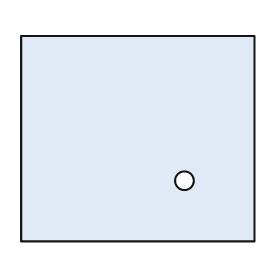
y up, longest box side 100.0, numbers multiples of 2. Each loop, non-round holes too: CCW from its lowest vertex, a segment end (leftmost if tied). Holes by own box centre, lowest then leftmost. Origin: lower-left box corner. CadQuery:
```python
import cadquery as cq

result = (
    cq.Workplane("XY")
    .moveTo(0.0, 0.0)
    .lineTo(100.0, 0.0)
    .lineTo(100.0, 88.0)
    .lineTo(0.0, 88.0)
    .close()
    .moveTo(70.0, 26.0)
    .circle(4.0)
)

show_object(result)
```